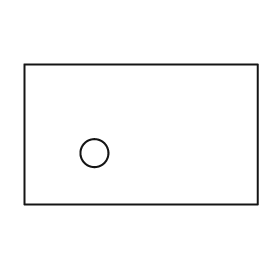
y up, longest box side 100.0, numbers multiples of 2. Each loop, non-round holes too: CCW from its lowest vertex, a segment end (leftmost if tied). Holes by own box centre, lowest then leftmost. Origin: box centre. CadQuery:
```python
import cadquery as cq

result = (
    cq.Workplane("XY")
    .moveTo(-50.0, -30.0)
    .lineTo(50.0, -30.0)
    .lineTo(50.0, 30.0)
    .lineTo(-50.0, 30.0)
    .close()
    .moveTo(-20.0, -8.0)
    .circle(6.0)
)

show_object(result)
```